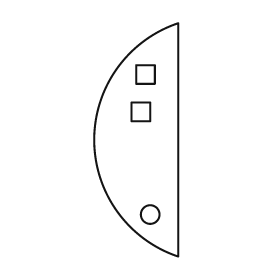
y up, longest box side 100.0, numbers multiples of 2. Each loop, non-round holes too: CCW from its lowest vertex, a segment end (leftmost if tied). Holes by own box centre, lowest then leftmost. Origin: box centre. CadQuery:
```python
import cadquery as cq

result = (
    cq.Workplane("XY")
    .moveTo(18.0, -50.0)
    .lineTo(18.0, 50.0)
    .threePointArc((-18.0, 0.0), (18.0, -50.0))
    .close()
    .moveTo(6.0, -32.0)
    .circle(4.0)
    .moveTo(-2.0, 8.0)
    .lineTo(6.0, 8.0)
    .lineTo(6.0, 16.0)
    .lineTo(-2.0, 16.0)
    .close()
    .moveTo(0.0, 24.0)
    .lineTo(8.0, 24.0)
    .lineTo(8.0, 32.0)
    .lineTo(0.0, 32.0)
    .close()
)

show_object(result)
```